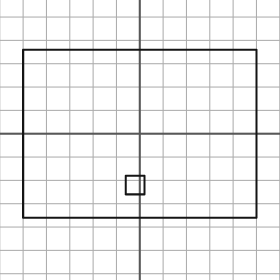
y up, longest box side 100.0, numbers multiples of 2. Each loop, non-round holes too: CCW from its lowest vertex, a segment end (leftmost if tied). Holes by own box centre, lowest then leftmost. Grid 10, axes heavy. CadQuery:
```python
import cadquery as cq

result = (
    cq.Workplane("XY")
    .moveTo(-50.0, -36.0)
    .lineTo(50.0, -36.0)
    .lineTo(50.0, 36.0)
    .lineTo(-50.0, 36.0)
    .close()
    .moveTo(-6.0, -26.0)
    .lineTo(2.0, -26.0)
    .lineTo(2.0, -18.0)
    .lineTo(-6.0, -18.0)
    .close()
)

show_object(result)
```